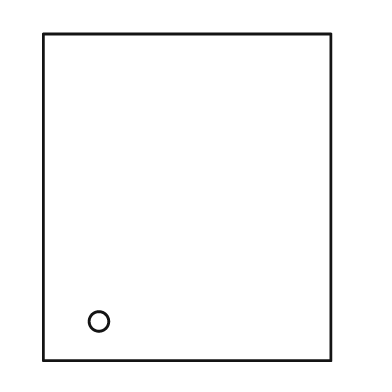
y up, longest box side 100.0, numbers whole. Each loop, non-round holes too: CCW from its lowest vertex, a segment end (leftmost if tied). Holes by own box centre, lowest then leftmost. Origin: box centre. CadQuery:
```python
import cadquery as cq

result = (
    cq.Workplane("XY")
    .moveTo(-44.0, -50.0)
    .lineTo(44.0, -50.0)
    .lineTo(44.0, 50.0)
    .lineTo(-44.0, 50.0)
    .close()
    .moveTo(-27.0, -38.0)
    .circle(3.0)
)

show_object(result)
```